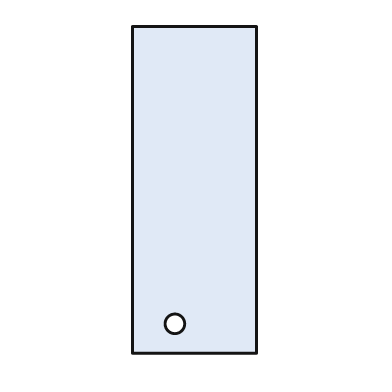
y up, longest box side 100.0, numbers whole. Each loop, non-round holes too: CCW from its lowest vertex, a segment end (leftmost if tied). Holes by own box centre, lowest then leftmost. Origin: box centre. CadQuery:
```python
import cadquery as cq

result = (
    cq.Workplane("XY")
    .moveTo(-19.0, -50.0)
    .lineTo(19.0, -50.0)
    .lineTo(19.0, 50.0)
    .lineTo(-19.0, 50.0)
    .close()
    .moveTo(-6.0, -41.0)
    .circle(3.0)
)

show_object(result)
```